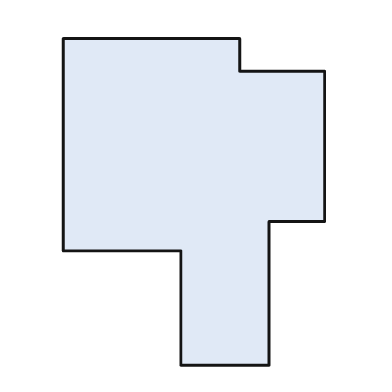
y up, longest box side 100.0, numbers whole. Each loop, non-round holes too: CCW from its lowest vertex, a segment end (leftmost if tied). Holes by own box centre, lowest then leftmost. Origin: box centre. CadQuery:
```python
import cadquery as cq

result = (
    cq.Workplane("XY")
    .moveTo(-4.0, -50.0)
    .lineTo(23.0, -50.0)
    .lineTo(23.0, -6.0)
    .lineTo(40.0, -6.0)
    .lineTo(40.0, 40.0)
    .lineTo(14.0, 40.0)
    .lineTo(14.0, 50.0)
    .lineTo(-40.0, 50.0)
    .lineTo(-40.0, -15.0)
    .lineTo(-4.0, -15.0)
    .close()
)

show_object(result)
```